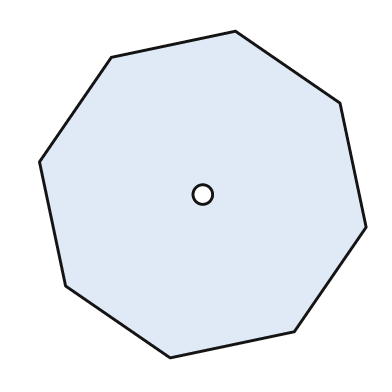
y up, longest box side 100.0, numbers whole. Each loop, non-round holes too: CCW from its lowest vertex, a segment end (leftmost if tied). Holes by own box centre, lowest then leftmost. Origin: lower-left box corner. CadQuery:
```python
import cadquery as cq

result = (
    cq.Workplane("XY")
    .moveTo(40.0, 0.0)
    .lineTo(78.0, 8.0)
    .lineTo(100.0, 40.0)
    .lineTo(92.0, 78.0)
    .lineTo(60.0, 100.0)
    .lineTo(22.0, 92.0)
    .lineTo(0.0, 60.0)
    .lineTo(8.0, 22.0)
    .close()
    .moveTo(50.0, 50.0)
    .circle(3.0)
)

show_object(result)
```